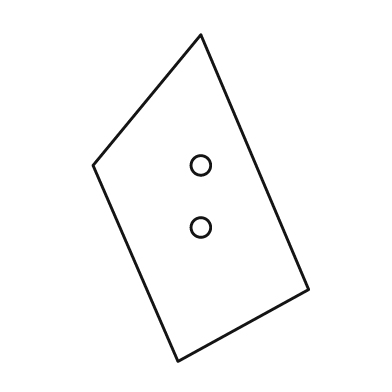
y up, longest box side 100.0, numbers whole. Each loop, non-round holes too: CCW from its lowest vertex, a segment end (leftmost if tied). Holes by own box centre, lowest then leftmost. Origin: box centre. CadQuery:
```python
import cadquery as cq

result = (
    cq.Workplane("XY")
    .moveTo(-7.0, -50.0)
    .lineTo(33.0, -28.0)
    .lineTo(0.0, 50.0)
    .lineTo(-33.0, 10.0)
    .close()
    .moveTo(0.0, -9.0)
    .circle(3.0)
    .moveTo(0.0, 10.0)
    .circle(3.0)
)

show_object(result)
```